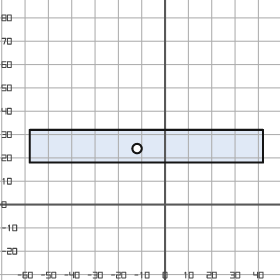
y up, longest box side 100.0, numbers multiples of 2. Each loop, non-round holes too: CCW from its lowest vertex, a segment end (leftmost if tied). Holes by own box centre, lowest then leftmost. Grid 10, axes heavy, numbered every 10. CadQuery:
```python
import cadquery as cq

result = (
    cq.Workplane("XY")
    .moveTo(-58.0, 18.0)
    .lineTo(42.0, 18.0)
    .lineTo(42.0, 32.0)
    .lineTo(-58.0, 32.0)
    .close()
    .moveTo(-12.0, 24.0)
    .circle(2.0)
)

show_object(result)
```